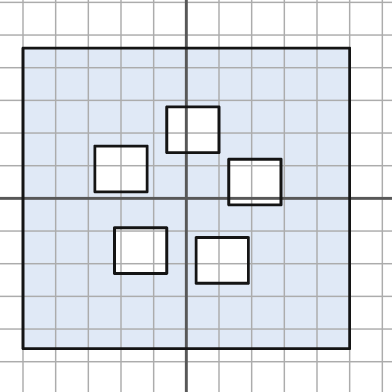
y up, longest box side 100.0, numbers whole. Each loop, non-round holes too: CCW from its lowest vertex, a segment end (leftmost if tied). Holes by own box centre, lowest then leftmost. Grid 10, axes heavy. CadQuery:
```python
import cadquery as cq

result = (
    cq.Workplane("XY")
    .moveTo(-50.0, -46.0)
    .lineTo(50.0, -46.0)
    .lineTo(50.0, 46.0)
    .lineTo(-50.0, 46.0)
    .close()
    .moveTo(3.0, -26.0)
    .lineTo(19.0, -26.0)
    .lineTo(19.0, -12.0)
    .lineTo(3.0, -12.0)
    .close()
    .moveTo(-22.0, -23.0)
    .lineTo(-6.0, -23.0)
    .lineTo(-6.0, -9.0)
    .lineTo(-22.0, -9.0)
    .close()
    .moveTo(13.0, -2.0)
    .lineTo(29.0, -2.0)
    .lineTo(29.0, 12.0)
    .lineTo(13.0, 12.0)
    .close()
    .moveTo(-28.0, 2.0)
    .lineTo(-12.0, 2.0)
    .lineTo(-12.0, 16.0)
    .lineTo(-28.0, 16.0)
    .close()
    .moveTo(-6.0, 14.0)
    .lineTo(10.0, 14.0)
    .lineTo(10.0, 28.0)
    .lineTo(-6.0, 28.0)
    .close()
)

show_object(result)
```